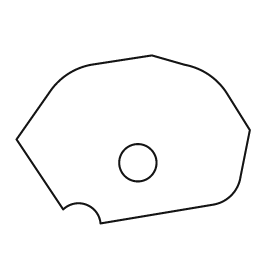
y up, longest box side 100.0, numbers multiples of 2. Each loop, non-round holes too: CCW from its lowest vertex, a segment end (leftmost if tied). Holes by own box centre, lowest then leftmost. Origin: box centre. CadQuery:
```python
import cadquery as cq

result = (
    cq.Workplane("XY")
    .moveTo(-14.0, -36.0)
    .lineTo(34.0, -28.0)
    .threePointArc((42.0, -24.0), (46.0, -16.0))
    .lineTo(50.0, 4.0)
    .lineTo(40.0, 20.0)
    .threePointArc((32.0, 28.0), (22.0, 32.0))
    .lineTo(8.0, 36.0)
    .lineTo(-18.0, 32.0)
    .threePointArc((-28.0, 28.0), (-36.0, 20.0))
    .lineTo(-50.0, 0.0)
    .lineTo(-30.0, -30.0)
    .threePointArc((-20.0, -28.0), (-14.0, -36.0))
    .close()
    .moveTo(2.0, -10.0)
    .circle(8.0)
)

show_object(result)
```